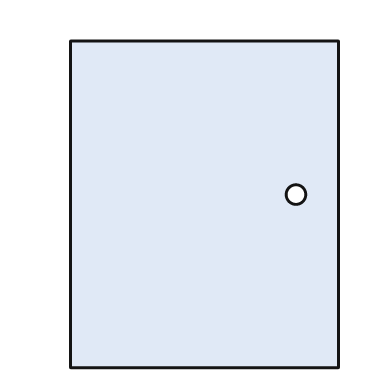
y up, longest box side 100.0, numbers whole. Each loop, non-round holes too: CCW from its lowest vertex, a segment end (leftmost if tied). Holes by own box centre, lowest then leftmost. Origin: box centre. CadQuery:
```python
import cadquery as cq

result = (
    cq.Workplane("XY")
    .moveTo(-41.0, -50.0)
    .lineTo(41.0, -50.0)
    .lineTo(41.0, 50.0)
    .lineTo(-41.0, 50.0)
    .close()
    .moveTo(28.0, 3.0)
    .circle(3.0)
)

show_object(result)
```